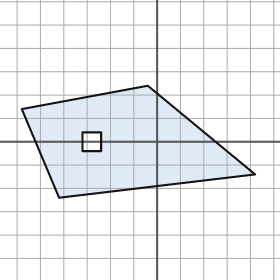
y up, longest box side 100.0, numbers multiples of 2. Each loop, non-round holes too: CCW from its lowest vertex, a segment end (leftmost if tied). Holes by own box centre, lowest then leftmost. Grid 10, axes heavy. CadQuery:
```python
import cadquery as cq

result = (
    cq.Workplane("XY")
    .moveTo(-42.0, -24.0)
    .lineTo(42.0, -14.0)
    .lineTo(-4.0, 24.0)
    .lineTo(-58.0, 14.0)
    .close()
    .moveTo(-32.0, -4.0)
    .lineTo(-24.0, -4.0)
    .lineTo(-24.0, 4.0)
    .lineTo(-32.0, 4.0)
    .close()
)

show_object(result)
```